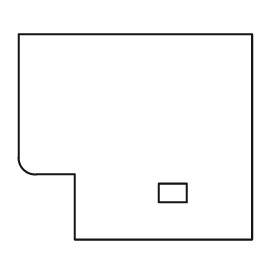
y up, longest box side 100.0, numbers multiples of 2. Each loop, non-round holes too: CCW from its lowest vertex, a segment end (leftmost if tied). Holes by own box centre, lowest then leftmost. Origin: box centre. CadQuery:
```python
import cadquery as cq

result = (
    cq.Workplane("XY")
    .moveTo(-26.0, -44.0)
    .lineTo(50.0, -44.0)
    .lineTo(50.0, 44.0)
    .lineTo(-50.0, 44.0)
    .lineTo(-50.0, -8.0)
    .threePointArc((-48.0, -14.0), (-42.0, -16.0))
    .lineTo(-26.0, -16.0)
    .close()
    .moveTo(10.0, -28.0)
    .lineTo(22.0, -28.0)
    .lineTo(22.0, -20.0)
    .lineTo(10.0, -20.0)
    .close()
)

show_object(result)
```